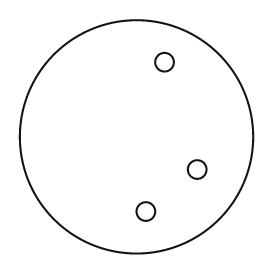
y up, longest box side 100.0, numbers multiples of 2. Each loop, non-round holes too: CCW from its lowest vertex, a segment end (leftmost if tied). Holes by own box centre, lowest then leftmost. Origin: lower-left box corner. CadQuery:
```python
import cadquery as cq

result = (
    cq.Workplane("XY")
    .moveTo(50.0, 50.0)
    .circle(50.0)
    .moveTo(54.0, 18.0)
    .circle(4.0)
    .moveTo(76.0, 36.0)
    .circle(4.0)
    .moveTo(62.0, 82.0)
    .circle(4.0)
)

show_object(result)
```